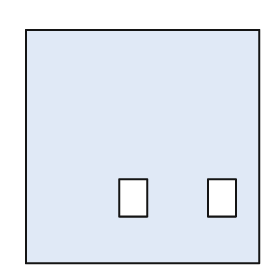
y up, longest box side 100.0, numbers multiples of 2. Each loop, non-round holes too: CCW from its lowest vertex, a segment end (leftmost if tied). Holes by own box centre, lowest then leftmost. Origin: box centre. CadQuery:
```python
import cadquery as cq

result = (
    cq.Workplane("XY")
    .moveTo(-50.0, -50.0)
    .lineTo(50.0, -50.0)
    .lineTo(50.0, 50.0)
    .lineTo(-50.0, 50.0)
    .close()
    .moveTo(-10.0, -30.0)
    .lineTo(2.0, -30.0)
    .lineTo(2.0, -14.0)
    .lineTo(-10.0, -14.0)
    .close()
    .moveTo(28.0, -30.0)
    .lineTo(40.0, -30.0)
    .lineTo(40.0, -14.0)
    .lineTo(28.0, -14.0)
    .close()
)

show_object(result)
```